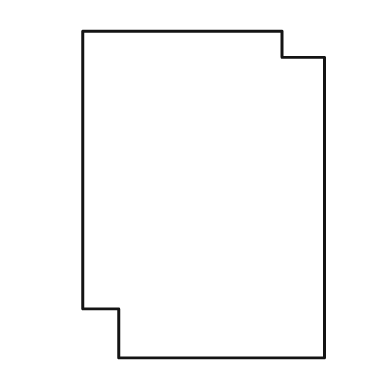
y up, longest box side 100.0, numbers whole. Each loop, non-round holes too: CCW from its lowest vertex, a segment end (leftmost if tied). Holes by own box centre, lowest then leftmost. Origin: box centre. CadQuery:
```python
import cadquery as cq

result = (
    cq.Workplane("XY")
    .moveTo(-26.0, -50.0)
    .lineTo(37.0, -50.0)
    .lineTo(37.0, 42.0)
    .lineTo(24.0, 42.0)
    .lineTo(24.0, 50.0)
    .lineTo(-37.0, 50.0)
    .lineTo(-37.0, -35.0)
    .lineTo(-26.0, -35.0)
    .close()
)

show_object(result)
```